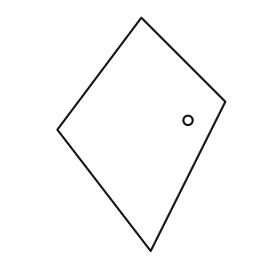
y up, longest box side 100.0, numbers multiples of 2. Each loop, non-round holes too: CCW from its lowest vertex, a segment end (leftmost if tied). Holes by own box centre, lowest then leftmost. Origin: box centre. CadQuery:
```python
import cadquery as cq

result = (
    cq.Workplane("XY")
    .moveTo(4.0, -50.0)
    .lineTo(36.0, 14.0)
    .lineTo(0.0, 50.0)
    .lineTo(-36.0, 2.0)
    .close()
    .moveTo(20.0, 6.0)
    .circle(2.0)
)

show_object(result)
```